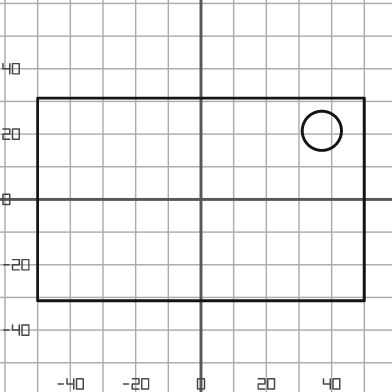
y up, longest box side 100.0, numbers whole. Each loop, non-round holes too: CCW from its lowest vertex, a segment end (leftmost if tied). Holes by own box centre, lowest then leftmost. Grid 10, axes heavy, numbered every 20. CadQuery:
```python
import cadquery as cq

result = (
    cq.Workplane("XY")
    .moveTo(-50.0, -31.0)
    .lineTo(50.0, -31.0)
    .lineTo(50.0, 31.0)
    .lineTo(-50.0, 31.0)
    .close()
    .moveTo(37.0, 21.0)
    .circle(6.0)
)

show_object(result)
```